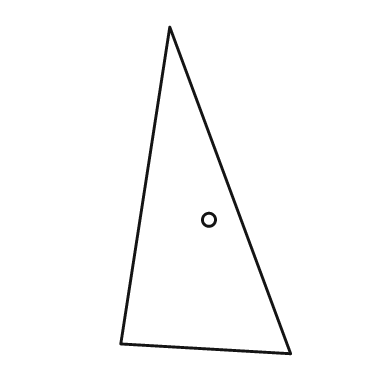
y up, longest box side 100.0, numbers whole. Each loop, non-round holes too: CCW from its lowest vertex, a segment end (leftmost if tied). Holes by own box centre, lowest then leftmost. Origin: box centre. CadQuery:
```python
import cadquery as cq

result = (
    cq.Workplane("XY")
    .moveTo(26.0, -50.0)
    .lineTo(-11.0, 50.0)
    .lineTo(-26.0, -47.0)
    .close()
    .moveTo(1.0, -9.0)
    .circle(2.0)
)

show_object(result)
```